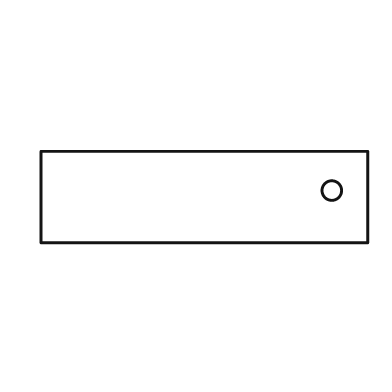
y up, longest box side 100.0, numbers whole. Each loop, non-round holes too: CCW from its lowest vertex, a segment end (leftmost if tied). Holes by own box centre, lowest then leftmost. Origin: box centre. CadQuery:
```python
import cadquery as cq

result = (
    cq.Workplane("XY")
    .moveTo(-50.0, -14.0)
    .lineTo(50.0, -14.0)
    .lineTo(50.0, 14.0)
    .lineTo(-50.0, 14.0)
    .close()
    .moveTo(39.0, 2.0)
    .circle(3.0)
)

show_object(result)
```